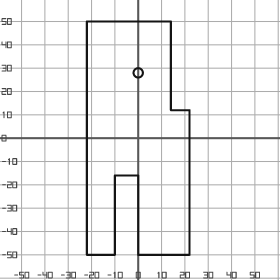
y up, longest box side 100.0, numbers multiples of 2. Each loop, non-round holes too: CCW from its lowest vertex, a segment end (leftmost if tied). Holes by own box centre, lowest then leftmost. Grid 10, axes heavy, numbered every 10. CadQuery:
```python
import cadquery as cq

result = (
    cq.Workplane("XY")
    .moveTo(-22.0, -50.0)
    .lineTo(-10.0, -50.0)
    .lineTo(-10.0, -16.0)
    .lineTo(0.0, -16.0)
    .lineTo(0.0, -50.0)
    .lineTo(22.0, -50.0)
    .lineTo(22.0, 12.0)
    .lineTo(14.0, 12.0)
    .lineTo(14.0, 50.0)
    .lineTo(-22.0, 50.0)
    .close()
    .moveTo(0.0, 28.0)
    .circle(2.0)
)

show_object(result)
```